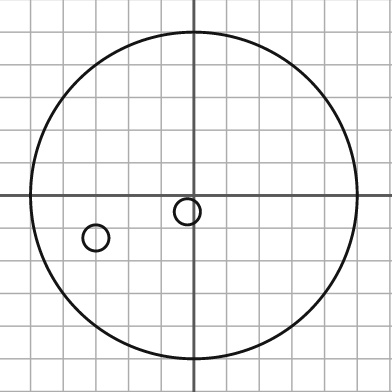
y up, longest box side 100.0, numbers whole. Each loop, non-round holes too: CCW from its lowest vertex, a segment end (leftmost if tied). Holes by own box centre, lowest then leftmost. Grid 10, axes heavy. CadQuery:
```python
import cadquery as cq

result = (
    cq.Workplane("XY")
    .moveTo(0.0, 0.0)
    .circle(50.0)
    .moveTo(-30.0, -13.0)
    .circle(4.0)
    .moveTo(-2.0, -5.0)
    .circle(4.0)
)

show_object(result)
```